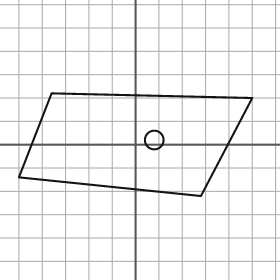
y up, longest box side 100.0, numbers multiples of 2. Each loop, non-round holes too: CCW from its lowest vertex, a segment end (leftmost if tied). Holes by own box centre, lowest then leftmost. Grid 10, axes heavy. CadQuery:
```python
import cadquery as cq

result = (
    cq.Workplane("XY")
    .moveTo(28.0, -22.0)
    .lineTo(50.0, 20.0)
    .lineTo(-36.0, 22.0)
    .lineTo(-50.0, -14.0)
    .close()
    .moveTo(8.0, 2.0)
    .circle(4.0)
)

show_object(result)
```